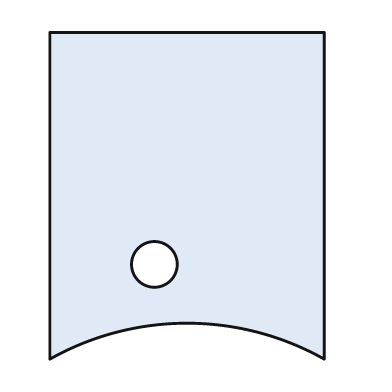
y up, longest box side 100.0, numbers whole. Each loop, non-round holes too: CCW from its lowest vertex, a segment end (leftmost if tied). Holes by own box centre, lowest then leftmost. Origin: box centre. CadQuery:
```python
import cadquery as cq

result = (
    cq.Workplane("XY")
    .moveTo(-42.0, -50.0)
    .threePointArc((0.0, -39.0), (42.0, -50.0))
    .lineTo(42.0, 50.0)
    .lineTo(-42.0, 50.0)
    .close()
    .moveTo(-10.0, -21.0)
    .circle(7.0)
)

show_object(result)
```